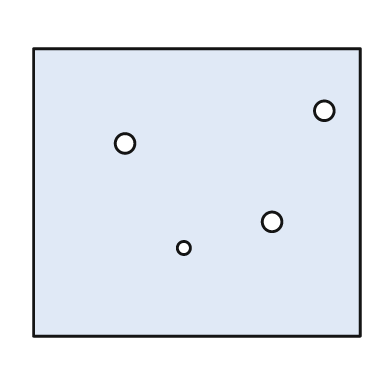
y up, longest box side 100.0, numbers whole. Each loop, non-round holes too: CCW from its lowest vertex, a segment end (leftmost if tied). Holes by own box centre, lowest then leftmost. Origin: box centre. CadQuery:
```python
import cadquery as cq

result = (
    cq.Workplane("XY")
    .moveTo(-50.0, -44.0)
    .lineTo(50.0, -44.0)
    .lineTo(50.0, 44.0)
    .lineTo(-50.0, 44.0)
    .close()
    .moveTo(-4.0, -17.0)
    .circle(2.0)
    .moveTo(23.0, -9.0)
    .circle(3.0)
    .moveTo(-22.0, 15.0)
    .circle(3.0)
    .moveTo(39.0, 25.0)
    .circle(3.0)
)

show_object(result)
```